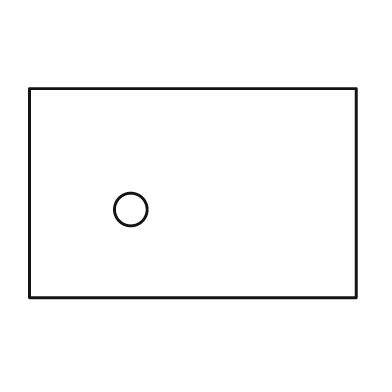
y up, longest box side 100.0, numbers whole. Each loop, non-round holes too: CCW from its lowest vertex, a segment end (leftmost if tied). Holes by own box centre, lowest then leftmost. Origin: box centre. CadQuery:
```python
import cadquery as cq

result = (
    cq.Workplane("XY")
    .moveTo(-50.0, -32.0)
    .lineTo(50.0, -32.0)
    .lineTo(50.0, 32.0)
    .lineTo(-50.0, 32.0)
    .close()
    .moveTo(-19.0, -5.0)
    .circle(5.0)
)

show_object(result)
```